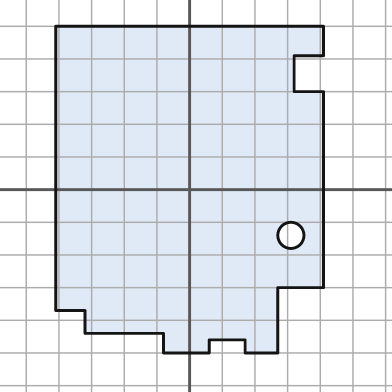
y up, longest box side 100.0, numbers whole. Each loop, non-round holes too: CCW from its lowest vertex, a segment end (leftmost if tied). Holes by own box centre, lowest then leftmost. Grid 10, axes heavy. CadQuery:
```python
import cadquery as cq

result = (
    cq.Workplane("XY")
    .moveTo(-8.0, -50.0)
    .lineTo(6.0, -50.0)
    .lineTo(6.0, -46.0)
    .lineTo(17.0, -46.0)
    .lineTo(17.0, -50.0)
    .lineTo(27.0, -50.0)
    .lineTo(27.0, -30.0)
    .lineTo(41.0, -30.0)
    .lineTo(41.0, 30.0)
    .lineTo(32.0, 30.0)
    .lineTo(32.0, 41.0)
    .lineTo(41.0, 41.0)
    .lineTo(41.0, 50.0)
    .lineTo(-41.0, 50.0)
    .lineTo(-41.0, -37.0)
    .lineTo(-32.0, -37.0)
    .lineTo(-32.0, -44.0)
    .lineTo(-8.0, -44.0)
    .close()
    .moveTo(31.0, -14.0)
    .circle(4.0)
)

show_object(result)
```